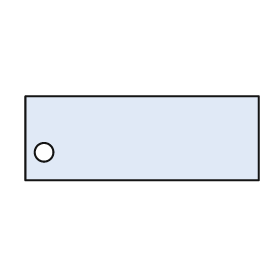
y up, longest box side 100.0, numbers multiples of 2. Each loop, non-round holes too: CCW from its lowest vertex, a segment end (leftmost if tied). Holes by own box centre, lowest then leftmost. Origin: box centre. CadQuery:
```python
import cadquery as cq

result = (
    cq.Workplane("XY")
    .moveTo(-50.0, -18.0)
    .lineTo(50.0, -18.0)
    .lineTo(50.0, 18.0)
    .lineTo(-50.0, 18.0)
    .close()
    .moveTo(-42.0, -6.0)
    .circle(4.0)
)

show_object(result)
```